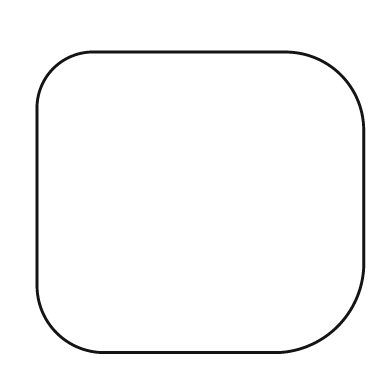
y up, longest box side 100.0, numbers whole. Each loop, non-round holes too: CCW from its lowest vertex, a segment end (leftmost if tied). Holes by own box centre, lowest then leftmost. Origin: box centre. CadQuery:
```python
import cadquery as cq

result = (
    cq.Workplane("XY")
    .moveTo(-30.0, -46.0)
    .lineTo(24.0, -46.0)
    .threePointArc((42.0, -38.0), (50.0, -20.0))
    .lineTo(50.0, 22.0)
    .threePointArc((43.0, 39.0), (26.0, 46.0))
    .lineTo(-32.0, 46.0)
    .threePointArc((-45.0, 41.0), (-50.0, 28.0))
    .lineTo(-50.0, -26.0)
    .threePointArc((-44.0, -40.0), (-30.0, -46.0))
    .close()
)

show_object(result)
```